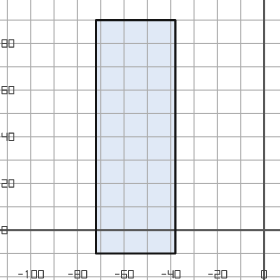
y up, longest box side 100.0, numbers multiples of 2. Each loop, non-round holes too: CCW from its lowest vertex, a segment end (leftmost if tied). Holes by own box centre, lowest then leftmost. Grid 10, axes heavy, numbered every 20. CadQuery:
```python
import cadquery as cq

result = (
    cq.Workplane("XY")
    .moveTo(-72.0, -10.0)
    .lineTo(-38.0, -10.0)
    .lineTo(-38.0, 90.0)
    .lineTo(-72.0, 90.0)
    .close()
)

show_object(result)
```